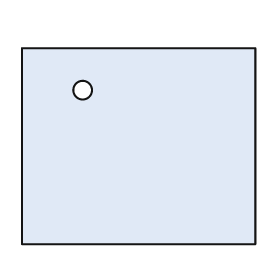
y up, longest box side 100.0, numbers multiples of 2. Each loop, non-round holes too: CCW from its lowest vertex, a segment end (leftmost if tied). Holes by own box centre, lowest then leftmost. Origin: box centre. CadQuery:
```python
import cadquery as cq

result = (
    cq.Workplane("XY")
    .moveTo(-50.0, -42.0)
    .lineTo(50.0, -42.0)
    .lineTo(50.0, 42.0)
    .lineTo(-50.0, 42.0)
    .close()
    .moveTo(-24.0, 24.0)
    .circle(4.0)
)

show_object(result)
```